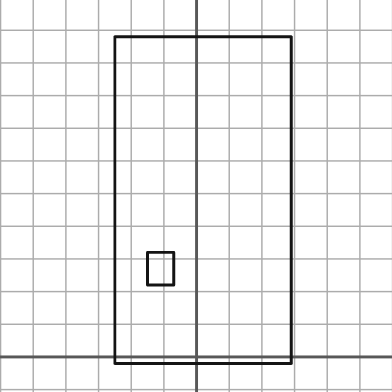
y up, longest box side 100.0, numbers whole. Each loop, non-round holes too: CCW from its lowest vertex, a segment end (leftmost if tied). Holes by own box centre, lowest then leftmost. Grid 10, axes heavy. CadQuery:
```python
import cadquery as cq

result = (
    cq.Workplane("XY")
    .moveTo(-25.0, -2.0)
    .lineTo(29.0, -2.0)
    .lineTo(29.0, 98.0)
    .lineTo(-25.0, 98.0)
    .close()
    .moveTo(-15.0, 22.0)
    .lineTo(-7.0, 22.0)
    .lineTo(-7.0, 32.0)
    .lineTo(-15.0, 32.0)
    .close()
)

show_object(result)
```